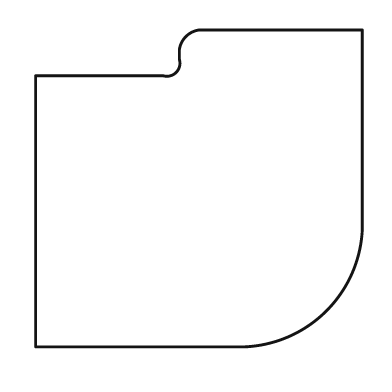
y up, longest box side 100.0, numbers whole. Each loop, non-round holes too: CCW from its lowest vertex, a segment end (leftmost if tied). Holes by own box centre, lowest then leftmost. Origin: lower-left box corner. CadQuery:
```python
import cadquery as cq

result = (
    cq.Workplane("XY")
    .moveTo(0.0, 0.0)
    .lineTo(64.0, 0.0)
    .threePointArc((89.0, 11.0), (100.0, 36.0))
    .lineTo(100.0, 97.0)
    .lineTo(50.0, 97.0)
    .threePointArc((46.0, 95.0), (44.0, 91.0))
    .lineTo(44.0, 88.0)
    .threePointArc((43.0, 84.0), (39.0, 83.0))
    .lineTo(0.0, 83.0)
    .close()
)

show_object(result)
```